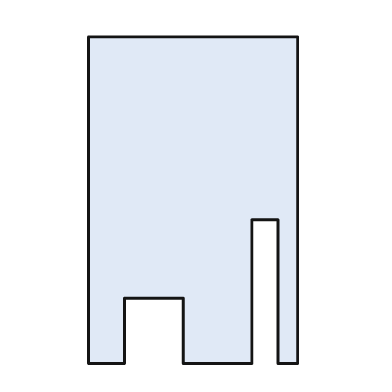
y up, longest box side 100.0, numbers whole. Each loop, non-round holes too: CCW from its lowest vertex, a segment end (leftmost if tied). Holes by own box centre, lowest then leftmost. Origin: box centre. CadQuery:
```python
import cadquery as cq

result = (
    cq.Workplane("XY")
    .moveTo(-32.0, -50.0)
    .lineTo(-21.0, -50.0)
    .lineTo(-21.0, -30.0)
    .lineTo(-3.0, -30.0)
    .lineTo(-3.0, -50.0)
    .lineTo(18.0, -50.0)
    .lineTo(18.0, -6.0)
    .lineTo(26.0, -6.0)
    .lineTo(26.0, -50.0)
    .lineTo(32.0, -50.0)
    .lineTo(32.0, 50.0)
    .lineTo(-32.0, 50.0)
    .close()
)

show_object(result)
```